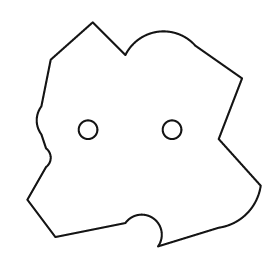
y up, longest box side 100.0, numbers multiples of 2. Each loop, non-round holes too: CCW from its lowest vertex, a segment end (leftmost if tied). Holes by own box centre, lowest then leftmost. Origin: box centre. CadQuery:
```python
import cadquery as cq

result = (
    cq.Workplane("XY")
    .moveTo(6.0, -48.0)
    .lineTo(32.0, -40.0)
    .threePointArc((44.0, -34.0), (50.0, -22.0))
    .lineTo(32.0, -2.0)
    .lineTo(42.0, 24.0)
    .lineTo(22.0, 38.0)
    .threePointArc((6.0, 44.0), (-8.0, 34.0))
    .lineTo(-22.0, 48.0)
    .lineTo(-40.0, 32.0)
    .lineTo(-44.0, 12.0)
    .threePointArc((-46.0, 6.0), (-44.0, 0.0))
    .lineTo(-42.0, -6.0)
    .threePointArc((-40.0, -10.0), (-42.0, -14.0))
    .lineTo(-50.0, -28.0)
    .lineTo(-38.0, -44.0)
    .lineTo(-8.0, -38.0)
    .threePointArc((4.0, -36.0), (6.0, -48.0))
    .close()
    .moveTo(-24.0, 2.0)
    .circle(4.0)
    .moveTo(12.0, 2.0)
    .circle(4.0)
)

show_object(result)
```